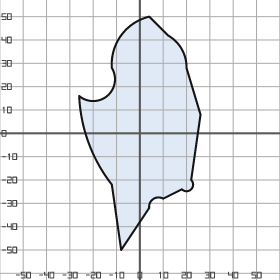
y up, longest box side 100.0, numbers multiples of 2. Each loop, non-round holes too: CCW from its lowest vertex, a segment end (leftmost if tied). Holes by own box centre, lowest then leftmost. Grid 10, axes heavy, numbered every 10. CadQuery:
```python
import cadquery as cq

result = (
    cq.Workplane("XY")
    .moveTo(-8.0, -50.0)
    .lineTo(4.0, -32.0)
    .threePointArc((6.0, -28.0), (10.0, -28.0))
    .lineTo(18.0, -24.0)
    .threePointArc((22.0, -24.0), (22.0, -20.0))
    .lineTo(26.0, 8.0)
    .lineTo(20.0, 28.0)
    .threePointArc((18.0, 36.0), (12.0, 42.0))
    .lineTo(4.0, 50.0)
    .threePointArc((-8.0, 42.0), (-12.0, 28.0))
    .threePointArc((-14.0, 16.0), (-26.0, 16.0))
    .threePointArc((-22.0, -4.0), (-12.0, -22.0))
    .close()
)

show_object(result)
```